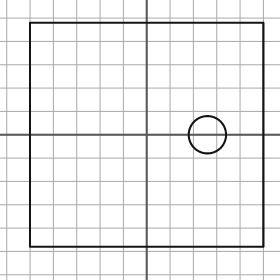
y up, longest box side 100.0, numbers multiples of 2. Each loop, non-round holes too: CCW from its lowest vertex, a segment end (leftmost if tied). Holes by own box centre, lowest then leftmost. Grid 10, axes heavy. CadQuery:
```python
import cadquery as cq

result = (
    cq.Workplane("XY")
    .moveTo(-50.0, -48.0)
    .lineTo(50.0, -48.0)
    .lineTo(50.0, 48.0)
    .lineTo(-50.0, 48.0)
    .close()
    .moveTo(26.0, 0.0)
    .circle(8.0)
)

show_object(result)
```